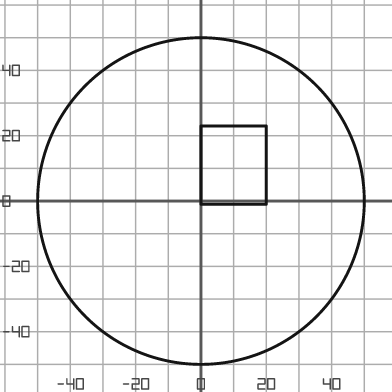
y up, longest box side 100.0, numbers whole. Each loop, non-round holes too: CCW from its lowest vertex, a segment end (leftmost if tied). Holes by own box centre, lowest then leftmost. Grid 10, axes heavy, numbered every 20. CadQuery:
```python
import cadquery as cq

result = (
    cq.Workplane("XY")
    .moveTo(0.0, 0.0)
    .circle(50.0)
    .moveTo(0.0, -1.0)
    .lineTo(20.0, -1.0)
    .lineTo(20.0, 23.0)
    .lineTo(0.0, 23.0)
    .close()
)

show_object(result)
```